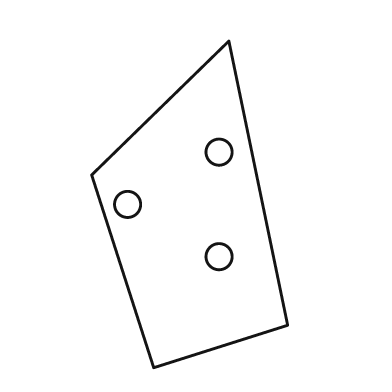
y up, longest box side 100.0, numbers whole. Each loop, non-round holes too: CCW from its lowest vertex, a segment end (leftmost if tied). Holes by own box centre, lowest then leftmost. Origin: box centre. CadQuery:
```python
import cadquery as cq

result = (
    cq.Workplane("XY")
    .moveTo(-11.0, -50.0)
    .lineTo(30.0, -37.0)
    .lineTo(12.0, 50.0)
    .lineTo(-30.0, 9.0)
    .close()
    .moveTo(9.0, -16.0)
    .circle(4.0)
    .moveTo(-19.0, 0.0)
    .circle(4.0)
    .moveTo(9.0, 16.0)
    .circle(4.0)
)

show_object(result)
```